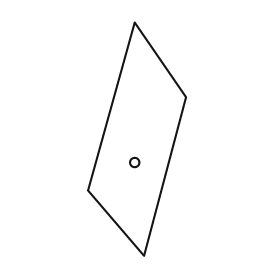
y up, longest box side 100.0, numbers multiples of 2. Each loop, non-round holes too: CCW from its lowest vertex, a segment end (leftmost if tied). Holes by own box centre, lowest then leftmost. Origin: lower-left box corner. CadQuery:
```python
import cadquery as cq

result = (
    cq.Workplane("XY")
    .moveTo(24.0, 0.0)
    .lineTo(42.0, 68.0)
    .lineTo(20.0, 100.0)
    .lineTo(0.0, 28.0)
    .close()
    .moveTo(20.0, 40.0)
    .circle(2.0)
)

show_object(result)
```